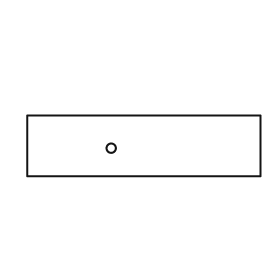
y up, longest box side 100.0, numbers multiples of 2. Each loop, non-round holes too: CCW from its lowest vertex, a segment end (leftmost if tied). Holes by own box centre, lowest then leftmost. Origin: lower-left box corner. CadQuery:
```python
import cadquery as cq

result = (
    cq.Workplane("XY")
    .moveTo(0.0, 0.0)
    .lineTo(100.0, 0.0)
    .lineTo(100.0, 26.0)
    .lineTo(0.0, 26.0)
    .close()
    .moveTo(36.0, 12.0)
    .circle(2.0)
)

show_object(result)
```